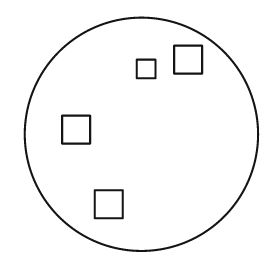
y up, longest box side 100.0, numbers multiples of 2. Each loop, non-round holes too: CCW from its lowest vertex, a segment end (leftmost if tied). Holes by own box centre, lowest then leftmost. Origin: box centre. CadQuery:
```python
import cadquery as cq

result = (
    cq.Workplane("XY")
    .moveTo(0.0, 0.0)
    .circle(50.0)
    .moveTo(-20.0, -36.0)
    .lineTo(-8.0, -36.0)
    .lineTo(-8.0, -24.0)
    .lineTo(-20.0, -24.0)
    .close()
    .moveTo(-34.0, -4.0)
    .lineTo(-22.0, -4.0)
    .lineTo(-22.0, 8.0)
    .lineTo(-34.0, 8.0)
    .close()
    .moveTo(-2.0, 24.0)
    .lineTo(6.0, 24.0)
    .lineTo(6.0, 32.0)
    .lineTo(-2.0, 32.0)
    .close()
    .moveTo(14.0, 26.0)
    .lineTo(26.0, 26.0)
    .lineTo(26.0, 38.0)
    .lineTo(14.0, 38.0)
    .close()
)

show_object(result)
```